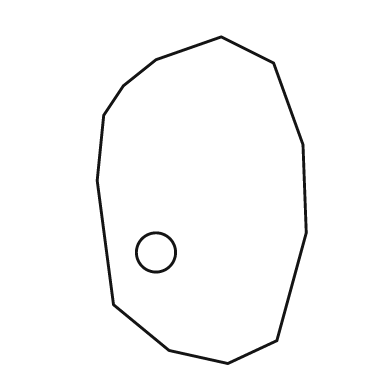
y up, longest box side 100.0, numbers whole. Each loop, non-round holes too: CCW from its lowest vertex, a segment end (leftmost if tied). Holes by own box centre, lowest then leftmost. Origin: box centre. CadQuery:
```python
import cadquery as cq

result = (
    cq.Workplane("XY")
    .moveTo(8.0, -50.0)
    .lineTo(23.0, -43.0)
    .lineTo(32.0, -10.0)
    .lineTo(31.0, 17.0)
    .lineTo(22.0, 42.0)
    .lineTo(6.0, 50.0)
    .lineTo(-14.0, 43.0)
    .lineTo(-24.0, 35.0)
    .lineTo(-30.0, 26.0)
    .lineTo(-32.0, 6.0)
    .lineTo(-27.0, -32.0)
    .lineTo(-10.0, -46.0)
    .close()
    .moveTo(-14.0, -16.0)
    .circle(6.0)
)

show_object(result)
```